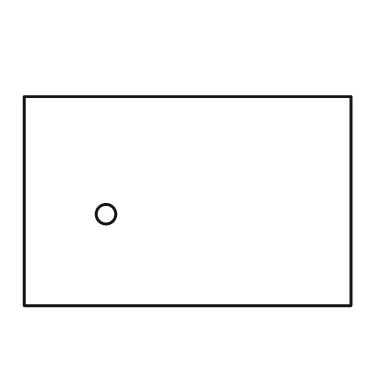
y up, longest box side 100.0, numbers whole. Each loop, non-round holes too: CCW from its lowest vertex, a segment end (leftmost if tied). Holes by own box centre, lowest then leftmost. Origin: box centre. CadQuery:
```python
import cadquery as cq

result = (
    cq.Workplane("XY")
    .moveTo(-50.0, -32.0)
    .lineTo(50.0, -32.0)
    .lineTo(50.0, 32.0)
    .lineTo(-50.0, 32.0)
    .close()
    .moveTo(-25.0, -4.0)
    .circle(3.0)
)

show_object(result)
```